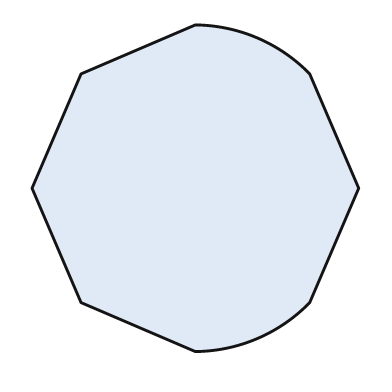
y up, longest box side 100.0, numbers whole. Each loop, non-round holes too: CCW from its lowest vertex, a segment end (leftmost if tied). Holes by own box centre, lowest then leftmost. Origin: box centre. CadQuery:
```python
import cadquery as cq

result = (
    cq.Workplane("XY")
    .moveTo(0.0, -50.0)
    .threePointArc((19.0, -46.0), (35.0, -35.0))
    .lineTo(50.0, 0.0)
    .lineTo(35.0, 35.0)
    .threePointArc((19.0, 46.0), (0.0, 50.0))
    .lineTo(-35.0, 35.0)
    .lineTo(-50.0, 0.0)
    .lineTo(-35.0, -35.0)
    .close()
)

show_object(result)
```